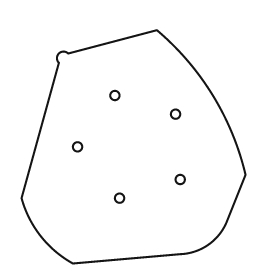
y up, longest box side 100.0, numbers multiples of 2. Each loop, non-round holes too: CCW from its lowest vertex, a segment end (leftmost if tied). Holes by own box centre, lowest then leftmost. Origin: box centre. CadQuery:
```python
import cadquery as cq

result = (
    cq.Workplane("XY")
    .moveTo(-26.0, -50.0)
    .lineTo(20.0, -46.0)
    .threePointArc((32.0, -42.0), (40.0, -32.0))
    .lineTo(48.0, -12.0)
    .threePointArc((34.0, 22.0), (10.0, 50.0))
    .lineTo(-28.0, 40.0)
    .threePointArc((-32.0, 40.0), (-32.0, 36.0))
    .lineTo(-48.0, -22.0)
    .threePointArc((-40.0, -38.0), (-26.0, -50.0))
    .close()
    .moveTo(-6.0, -22.0)
    .circle(2.0)
    .moveTo(20.0, -14.0)
    .circle(2.0)
    .moveTo(-24.0, 0.0)
    .circle(2.0)
    .moveTo(18.0, 14.0)
    .circle(2.0)
    .moveTo(-8.0, 22.0)
    .circle(2.0)
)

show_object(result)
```